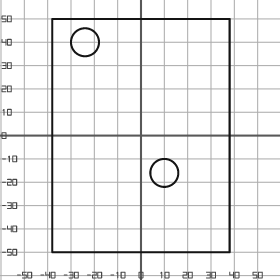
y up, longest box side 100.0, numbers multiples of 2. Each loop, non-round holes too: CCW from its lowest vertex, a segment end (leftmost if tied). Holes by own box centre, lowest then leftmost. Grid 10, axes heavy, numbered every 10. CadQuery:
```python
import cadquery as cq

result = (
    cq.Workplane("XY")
    .moveTo(-38.0, -50.0)
    .lineTo(38.0, -50.0)
    .lineTo(38.0, 50.0)
    .lineTo(-38.0, 50.0)
    .close()
    .moveTo(10.0, -16.0)
    .circle(6.0)
    .moveTo(-24.0, 40.0)
    .circle(6.0)
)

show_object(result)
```